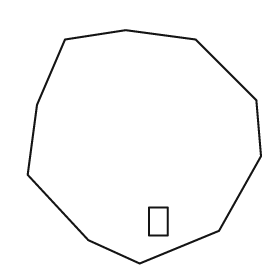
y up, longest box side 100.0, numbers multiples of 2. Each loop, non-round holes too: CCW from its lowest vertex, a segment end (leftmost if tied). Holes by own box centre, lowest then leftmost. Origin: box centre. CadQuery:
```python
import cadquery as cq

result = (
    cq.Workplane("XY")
    .moveTo(-2.0, -50.0)
    .lineTo(32.0, -36.0)
    .lineTo(50.0, -4.0)
    .lineTo(48.0, 20.0)
    .lineTo(22.0, 46.0)
    .lineTo(-8.0, 50.0)
    .lineTo(-34.0, 46.0)
    .lineTo(-46.0, 18.0)
    .lineTo(-50.0, -12.0)
    .lineTo(-24.0, -40.0)
    .close()
    .moveTo(2.0, -38.0)
    .lineTo(10.0, -38.0)
    .lineTo(10.0, -26.0)
    .lineTo(2.0, -26.0)
    .close()
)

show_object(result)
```